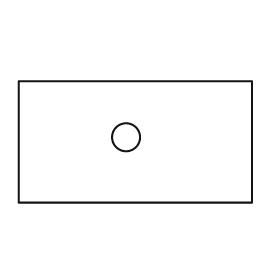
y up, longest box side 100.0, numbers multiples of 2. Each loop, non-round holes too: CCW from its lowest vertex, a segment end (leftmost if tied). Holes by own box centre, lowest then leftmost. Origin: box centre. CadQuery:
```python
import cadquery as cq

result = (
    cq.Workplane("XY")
    .moveTo(-50.0, -26.0)
    .lineTo(50.0, -26.0)
    .lineTo(50.0, 26.0)
    .lineTo(-50.0, 26.0)
    .close()
    .moveTo(-4.0, 2.0)
    .circle(6.0)
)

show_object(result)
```